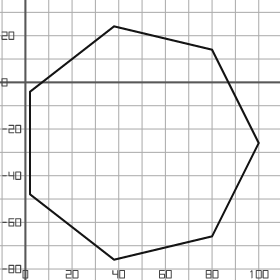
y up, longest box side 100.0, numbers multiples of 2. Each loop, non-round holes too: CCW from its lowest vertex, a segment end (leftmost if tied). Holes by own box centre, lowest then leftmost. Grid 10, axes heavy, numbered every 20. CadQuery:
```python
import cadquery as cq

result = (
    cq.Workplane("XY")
    .moveTo(38.0, -76.0)
    .lineTo(80.0, -66.0)
    .lineTo(100.0, -26.0)
    .lineTo(80.0, 14.0)
    .lineTo(38.0, 24.0)
    .lineTo(2.0, -4.0)
    .lineTo(2.0, -48.0)
    .close()
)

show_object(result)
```